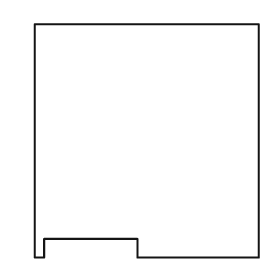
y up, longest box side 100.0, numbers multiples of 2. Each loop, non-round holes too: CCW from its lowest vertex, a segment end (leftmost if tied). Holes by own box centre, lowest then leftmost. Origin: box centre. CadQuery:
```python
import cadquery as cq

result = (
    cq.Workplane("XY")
    .moveTo(-48.0, -50.0)
    .lineTo(-44.0, -50.0)
    .lineTo(-44.0, -42.0)
    .lineTo(-4.0, -42.0)
    .lineTo(-4.0, -50.0)
    .lineTo(48.0, -50.0)
    .lineTo(48.0, 50.0)
    .lineTo(-48.0, 50.0)
    .close()
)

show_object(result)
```